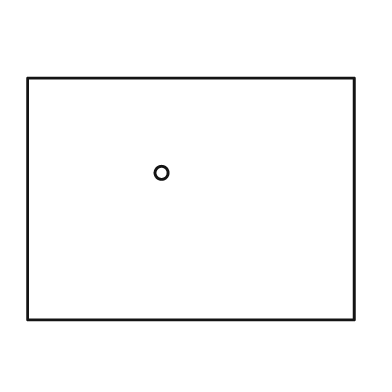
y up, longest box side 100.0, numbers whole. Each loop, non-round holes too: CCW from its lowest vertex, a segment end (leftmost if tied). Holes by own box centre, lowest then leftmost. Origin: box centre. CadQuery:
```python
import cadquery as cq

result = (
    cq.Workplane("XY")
    .moveTo(-50.0, -37.0)
    .lineTo(50.0, -37.0)
    .lineTo(50.0, 37.0)
    .lineTo(-50.0, 37.0)
    .close()
    .moveTo(-9.0, 8.0)
    .circle(2.0)
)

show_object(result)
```